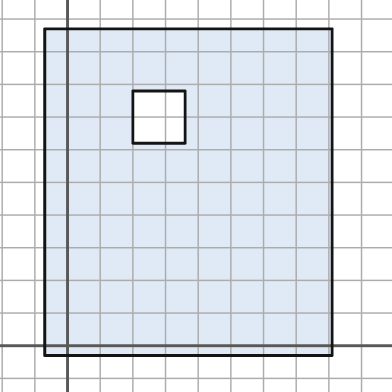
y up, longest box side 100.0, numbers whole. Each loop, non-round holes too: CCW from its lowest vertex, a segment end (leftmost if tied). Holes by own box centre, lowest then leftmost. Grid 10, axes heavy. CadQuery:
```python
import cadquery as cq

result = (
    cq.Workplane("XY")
    .moveTo(-7.0, -3.0)
    .lineTo(81.0, -3.0)
    .lineTo(81.0, 97.0)
    .lineTo(-7.0, 97.0)
    .close()
    .moveTo(20.0, 62.0)
    .lineTo(36.0, 62.0)
    .lineTo(36.0, 78.0)
    .lineTo(20.0, 78.0)
    .close()
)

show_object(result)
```